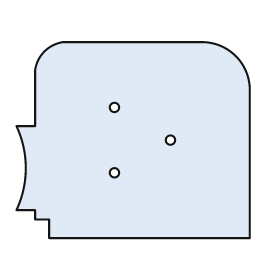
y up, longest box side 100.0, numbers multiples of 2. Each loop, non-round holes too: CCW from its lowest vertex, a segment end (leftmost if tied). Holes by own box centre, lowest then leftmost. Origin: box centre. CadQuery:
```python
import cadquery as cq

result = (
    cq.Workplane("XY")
    .moveTo(-36.0, -42.0)
    .lineTo(50.0, -42.0)
    .lineTo(50.0, 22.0)
    .threePointArc((44.0, 36.0), (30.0, 42.0))
    .lineTo(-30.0, 42.0)
    .threePointArc((-38.0, 38.0), (-42.0, 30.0))
    .lineTo(-42.0, 6.0)
    .lineTo(-50.0, 6.0)
    .threePointArc((-46.0, -12.0), (-50.0, -30.0))
    .lineTo(-42.0, -30.0)
    .lineTo(-42.0, -34.0)
    .lineTo(-36.0, -34.0)
    .close()
    .moveTo(-8.0, -14.0)
    .circle(2.0)
    .moveTo(16.0, 0.0)
    .circle(2.0)
    .moveTo(-8.0, 14.0)
    .circle(2.0)
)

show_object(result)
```